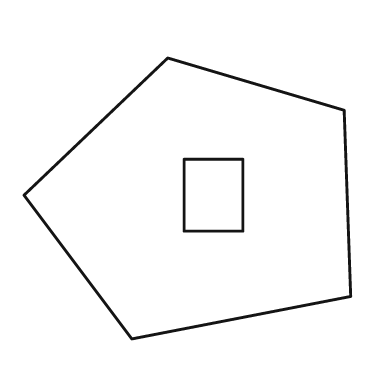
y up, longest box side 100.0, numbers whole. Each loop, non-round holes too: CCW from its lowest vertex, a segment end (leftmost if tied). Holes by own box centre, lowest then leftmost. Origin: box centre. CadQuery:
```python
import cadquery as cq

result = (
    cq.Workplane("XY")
    .moveTo(-17.0, -43.0)
    .lineTo(50.0, -30.0)
    .lineTo(48.0, 27.0)
    .lineTo(-6.0, 43.0)
    .lineTo(-50.0, 1.0)
    .close()
    .moveTo(-1.0, -10.0)
    .lineTo(17.0, -10.0)
    .lineTo(17.0, 12.0)
    .lineTo(-1.0, 12.0)
    .close()
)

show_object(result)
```